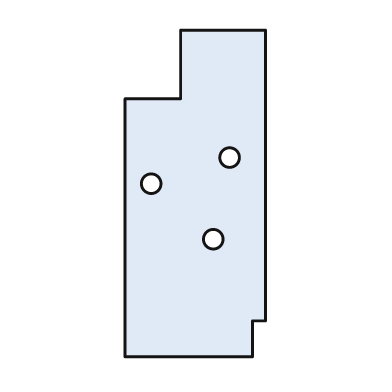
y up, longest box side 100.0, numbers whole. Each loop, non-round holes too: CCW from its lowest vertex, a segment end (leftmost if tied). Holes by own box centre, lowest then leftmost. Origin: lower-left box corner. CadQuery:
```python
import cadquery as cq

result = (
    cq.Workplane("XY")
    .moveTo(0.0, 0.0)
    .lineTo(39.0, 0.0)
    .lineTo(39.0, 11.0)
    .lineTo(43.0, 11.0)
    .lineTo(43.0, 100.0)
    .lineTo(17.0, 100.0)
    .lineTo(17.0, 79.0)
    .lineTo(0.0, 79.0)
    .close()
    .moveTo(27.0, 36.0)
    .circle(3.0)
    .moveTo(8.0, 53.0)
    .circle(3.0)
    .moveTo(32.0, 61.0)
    .circle(3.0)
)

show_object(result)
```